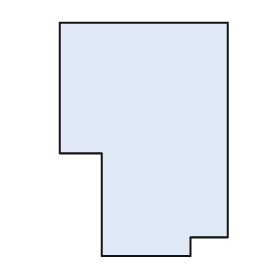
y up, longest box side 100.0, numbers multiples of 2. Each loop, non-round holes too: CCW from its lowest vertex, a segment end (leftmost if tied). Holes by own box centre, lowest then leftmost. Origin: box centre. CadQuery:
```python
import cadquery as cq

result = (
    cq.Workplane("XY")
    .moveTo(-18.0, -50.0)
    .lineTo(20.0, -50.0)
    .lineTo(20.0, -42.0)
    .lineTo(36.0, -42.0)
    .lineTo(36.0, 50.0)
    .lineTo(-36.0, 50.0)
    .lineTo(-36.0, -6.0)
    .lineTo(-18.0, -6.0)
    .close()
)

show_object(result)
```